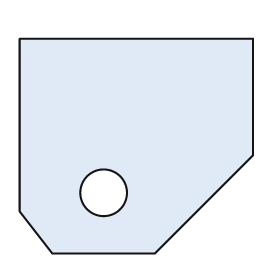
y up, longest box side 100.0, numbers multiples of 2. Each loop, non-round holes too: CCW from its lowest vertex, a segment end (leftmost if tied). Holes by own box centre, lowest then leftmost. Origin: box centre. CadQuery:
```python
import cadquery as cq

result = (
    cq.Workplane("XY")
    .moveTo(-36.0, -46.0)
    .lineTo(8.0, -46.0)
    .lineTo(50.0, -4.0)
    .lineTo(50.0, 46.0)
    .lineTo(-50.0, 46.0)
    .lineTo(-50.0, -28.0)
    .close()
    .moveTo(-14.0, -20.0)
    .circle(10.0)
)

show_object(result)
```